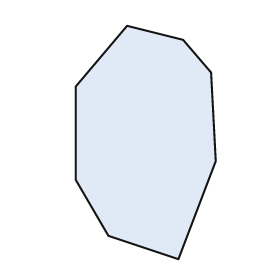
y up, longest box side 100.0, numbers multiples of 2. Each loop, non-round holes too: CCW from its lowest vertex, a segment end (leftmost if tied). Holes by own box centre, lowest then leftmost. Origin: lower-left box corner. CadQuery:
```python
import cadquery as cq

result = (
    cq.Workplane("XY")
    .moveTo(44.0, 0.0)
    .lineTo(60.0, 42.0)
    .lineTo(58.0, 80.0)
    .lineTo(46.0, 94.0)
    .lineTo(22.0, 100.0)
    .lineTo(0.0, 74.0)
    .lineTo(0.0, 34.0)
    .lineTo(14.0, 10.0)
    .close()
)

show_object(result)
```